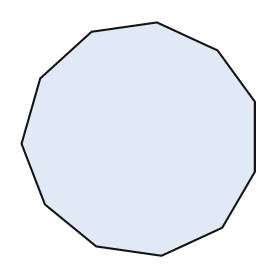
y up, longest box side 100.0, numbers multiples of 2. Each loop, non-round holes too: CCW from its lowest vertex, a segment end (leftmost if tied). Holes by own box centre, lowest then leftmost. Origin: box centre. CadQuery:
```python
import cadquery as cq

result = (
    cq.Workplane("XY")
    .moveTo(10.0, -50.0)
    .lineTo(36.0, -38.0)
    .lineTo(50.0, -14.0)
    .lineTo(50.0, 16.0)
    .lineTo(34.0, 38.0)
    .lineTo(8.0, 50.0)
    .lineTo(-20.0, 46.0)
    .lineTo(-42.0, 26.0)
    .lineTo(-50.0, -2.0)
    .lineTo(-40.0, -28.0)
    .lineTo(-18.0, -46.0)
    .close()
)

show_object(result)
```